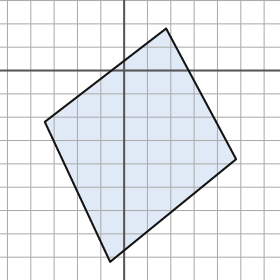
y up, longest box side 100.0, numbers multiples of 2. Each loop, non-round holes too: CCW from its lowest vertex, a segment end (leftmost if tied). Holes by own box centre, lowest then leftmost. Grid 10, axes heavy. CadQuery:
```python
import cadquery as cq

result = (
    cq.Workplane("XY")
    .moveTo(-6.0, -82.0)
    .lineTo(48.0, -38.0)
    .lineTo(18.0, 18.0)
    .lineTo(-34.0, -22.0)
    .close()
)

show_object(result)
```